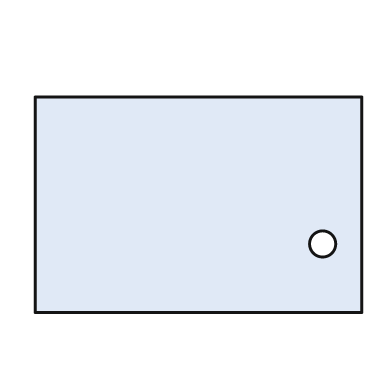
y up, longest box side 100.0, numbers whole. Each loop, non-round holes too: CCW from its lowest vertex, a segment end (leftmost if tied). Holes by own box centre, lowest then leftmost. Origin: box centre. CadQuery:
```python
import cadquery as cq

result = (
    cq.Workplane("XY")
    .moveTo(-50.0, -33.0)
    .lineTo(50.0, -33.0)
    .lineTo(50.0, 33.0)
    .lineTo(-50.0, 33.0)
    .close()
    .moveTo(38.0, -12.0)
    .circle(4.0)
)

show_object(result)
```